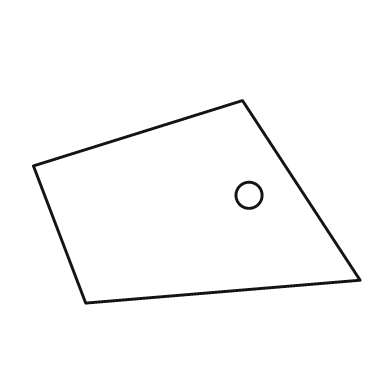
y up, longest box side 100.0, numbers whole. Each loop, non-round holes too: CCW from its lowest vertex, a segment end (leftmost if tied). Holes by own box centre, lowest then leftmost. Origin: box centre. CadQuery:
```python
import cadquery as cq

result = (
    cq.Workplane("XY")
    .moveTo(-34.0, -31.0)
    .lineTo(50.0, -24.0)
    .lineTo(14.0, 31.0)
    .lineTo(-50.0, 11.0)
    .close()
    .moveTo(16.0, 2.0)
    .circle(4.0)
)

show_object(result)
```